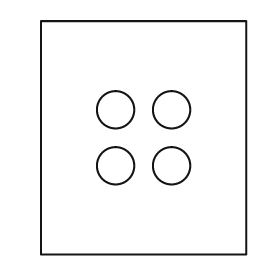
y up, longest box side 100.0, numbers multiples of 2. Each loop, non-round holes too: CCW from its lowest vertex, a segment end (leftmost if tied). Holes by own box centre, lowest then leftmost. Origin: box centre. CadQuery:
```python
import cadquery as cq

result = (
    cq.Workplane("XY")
    .moveTo(-44.0, -50.0)
    .lineTo(44.0, -50.0)
    .lineTo(44.0, 50.0)
    .lineTo(-44.0, 50.0)
    .close()
    .moveTo(-12.0, -12.0)
    .circle(8.0)
    .moveTo(12.0, -12.0)
    .circle(8.0)
    .moveTo(-12.0, 12.0)
    .circle(8.0)
    .moveTo(12.0, 12.0)
    .circle(8.0)
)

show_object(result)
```